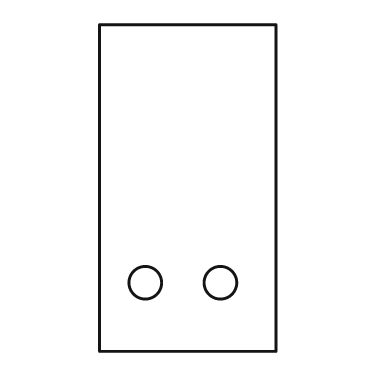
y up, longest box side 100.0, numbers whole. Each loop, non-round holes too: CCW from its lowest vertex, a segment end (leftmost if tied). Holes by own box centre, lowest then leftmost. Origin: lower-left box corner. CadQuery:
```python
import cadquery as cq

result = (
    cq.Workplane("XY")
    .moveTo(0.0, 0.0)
    .lineTo(54.0, 0.0)
    .lineTo(54.0, 100.0)
    .lineTo(0.0, 100.0)
    .close()
    .moveTo(14.0, 21.0)
    .circle(5.0)
    .moveTo(37.0, 21.0)
    .circle(5.0)
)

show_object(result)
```